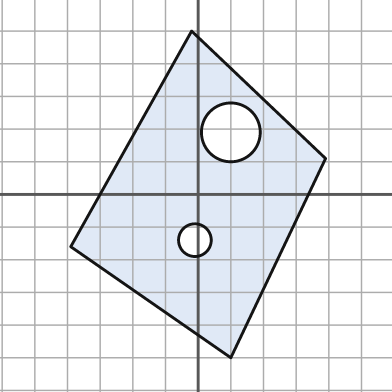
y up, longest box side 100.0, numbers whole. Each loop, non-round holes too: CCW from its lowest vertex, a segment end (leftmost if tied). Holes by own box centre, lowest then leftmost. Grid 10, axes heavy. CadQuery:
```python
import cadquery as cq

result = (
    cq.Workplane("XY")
    .moveTo(10.0, -50.0)
    .lineTo(39.0, 11.0)
    .lineTo(-2.0, 50.0)
    .lineTo(-39.0, -16.0)
    .close()
    .moveTo(-1.0, -14.0)
    .circle(5.0)
    .moveTo(10.0, 19.0)
    .circle(9.0)
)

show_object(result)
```